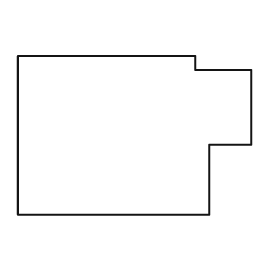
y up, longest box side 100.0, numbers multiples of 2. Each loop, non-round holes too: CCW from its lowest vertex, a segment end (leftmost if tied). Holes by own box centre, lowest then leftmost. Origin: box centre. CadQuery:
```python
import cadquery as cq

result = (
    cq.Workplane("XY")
    .moveTo(-50.0, -34.0)
    .lineTo(32.0, -34.0)
    .lineTo(32.0, -4.0)
    .lineTo(50.0, -4.0)
    .lineTo(50.0, 28.0)
    .lineTo(26.0, 28.0)
    .lineTo(26.0, 34.0)
    .lineTo(-50.0, 34.0)
    .close()
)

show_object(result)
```